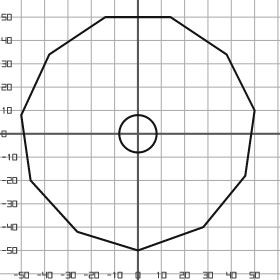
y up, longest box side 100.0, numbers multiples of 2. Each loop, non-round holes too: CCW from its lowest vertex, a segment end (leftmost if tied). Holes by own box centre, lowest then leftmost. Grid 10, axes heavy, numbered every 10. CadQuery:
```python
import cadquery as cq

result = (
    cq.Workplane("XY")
    .moveTo(0.0, -50.0)
    .lineTo(28.0, -40.0)
    .lineTo(46.0, -18.0)
    .lineTo(50.0, 10.0)
    .lineTo(38.0, 34.0)
    .lineTo(14.0, 50.0)
    .lineTo(-14.0, 50.0)
    .lineTo(-38.0, 34.0)
    .lineTo(-50.0, 8.0)
    .lineTo(-46.0, -20.0)
    .lineTo(-26.0, -42.0)
    .close()
    .moveTo(0.0, 0.0)
    .circle(8.0)
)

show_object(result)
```